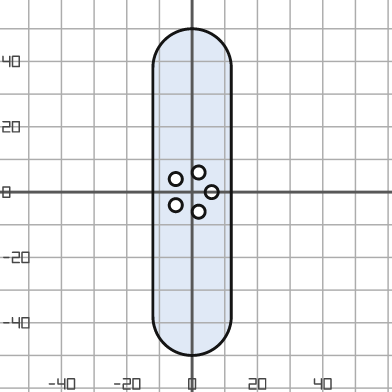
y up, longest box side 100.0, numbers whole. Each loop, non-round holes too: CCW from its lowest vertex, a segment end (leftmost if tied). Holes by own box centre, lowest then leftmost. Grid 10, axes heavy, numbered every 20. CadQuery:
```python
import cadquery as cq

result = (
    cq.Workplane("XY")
    .moveTo(-12.0, -38.0)
    .threePointArc((0.0, -50.0), (12.0, -38.0))
    .lineTo(12.0, 38.0)
    .threePointArc((0.0, 50.0), (-12.0, 38.0))
    .close()
    .moveTo(2.0, -6.0)
    .circle(2.0)
    .moveTo(-5.0, -4.0)
    .circle(2.0)
    .moveTo(6.0, 0.0)
    .circle(2.0)
    .moveTo(-5.0, 4.0)
    .circle(2.0)
    .moveTo(2.0, 6.0)
    .circle(2.0)
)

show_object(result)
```